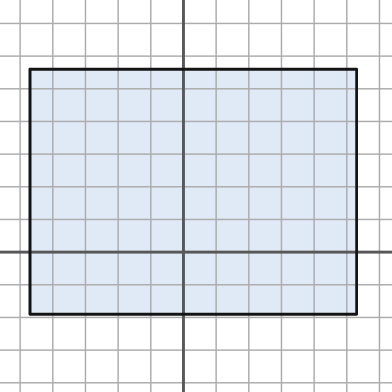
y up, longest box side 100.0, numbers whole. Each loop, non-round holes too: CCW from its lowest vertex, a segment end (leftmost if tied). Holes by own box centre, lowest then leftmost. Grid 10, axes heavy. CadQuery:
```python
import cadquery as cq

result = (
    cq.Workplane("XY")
    .moveTo(-47.0, -19.0)
    .lineTo(53.0, -19.0)
    .lineTo(53.0, 56.0)
    .lineTo(-47.0, 56.0)
    .close()
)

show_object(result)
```